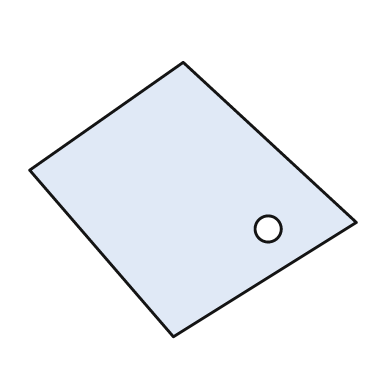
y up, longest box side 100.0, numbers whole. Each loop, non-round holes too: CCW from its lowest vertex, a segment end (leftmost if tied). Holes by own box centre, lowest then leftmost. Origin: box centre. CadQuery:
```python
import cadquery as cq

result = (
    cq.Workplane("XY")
    .moveTo(-6.0, -42.0)
    .lineTo(50.0, -7.0)
    .lineTo(-3.0, 42.0)
    .lineTo(-50.0, 9.0)
    .close()
    .moveTo(23.0, -9.0)
    .circle(4.0)
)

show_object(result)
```